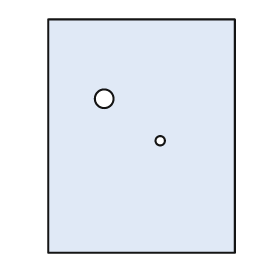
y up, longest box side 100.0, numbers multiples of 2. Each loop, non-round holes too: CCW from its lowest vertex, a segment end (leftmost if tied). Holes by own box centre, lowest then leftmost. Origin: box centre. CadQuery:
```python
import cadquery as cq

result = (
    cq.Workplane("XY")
    .moveTo(-40.0, -50.0)
    .lineTo(40.0, -50.0)
    .lineTo(40.0, 50.0)
    .lineTo(-40.0, 50.0)
    .close()
    .moveTo(8.0, -2.0)
    .circle(2.0)
    .moveTo(-16.0, 16.0)
    .circle(4.0)
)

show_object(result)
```